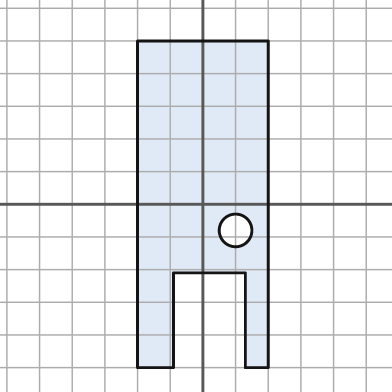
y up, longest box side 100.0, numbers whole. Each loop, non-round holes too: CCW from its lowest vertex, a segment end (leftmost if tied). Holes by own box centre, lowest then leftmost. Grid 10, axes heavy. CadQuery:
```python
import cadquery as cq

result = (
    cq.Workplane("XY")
    .moveTo(-20.0, -50.0)
    .lineTo(-9.0, -50.0)
    .lineTo(-9.0, -21.0)
    .lineTo(13.0, -21.0)
    .lineTo(13.0, -50.0)
    .lineTo(20.0, -50.0)
    .lineTo(20.0, 50.0)
    .lineTo(-20.0, 50.0)
    .close()
    .moveTo(10.0, -8.0)
    .circle(5.0)
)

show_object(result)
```